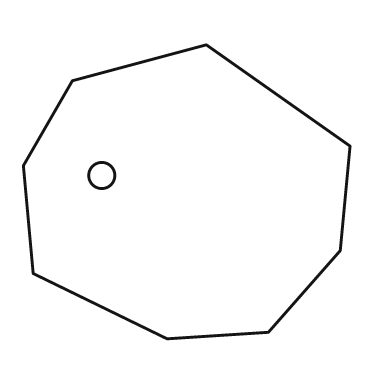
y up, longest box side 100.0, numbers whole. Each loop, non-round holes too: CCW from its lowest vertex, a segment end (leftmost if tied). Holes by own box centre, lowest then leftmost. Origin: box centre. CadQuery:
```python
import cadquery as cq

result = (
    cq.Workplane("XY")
    .moveTo(-6.0, -45.0)
    .lineTo(25.0, -43.0)
    .lineTo(47.0, -18.0)
    .lineTo(50.0, 14.0)
    .lineTo(6.0, 45.0)
    .lineTo(-35.0, 34.0)
    .lineTo(-50.0, 8.0)
    .lineTo(-47.0, -25.0)
    .close()
    .moveTo(-26.0, 5.0)
    .circle(4.0)
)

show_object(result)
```